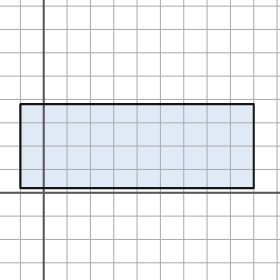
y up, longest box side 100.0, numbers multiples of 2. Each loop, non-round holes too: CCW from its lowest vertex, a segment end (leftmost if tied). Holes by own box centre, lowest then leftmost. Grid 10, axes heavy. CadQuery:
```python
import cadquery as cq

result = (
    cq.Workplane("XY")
    .moveTo(-10.0, 2.0)
    .lineTo(90.0, 2.0)
    .lineTo(90.0, 38.0)
    .lineTo(-10.0, 38.0)
    .close()
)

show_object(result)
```